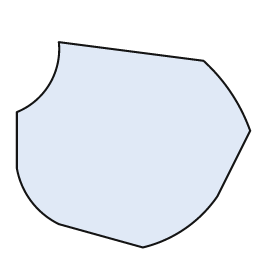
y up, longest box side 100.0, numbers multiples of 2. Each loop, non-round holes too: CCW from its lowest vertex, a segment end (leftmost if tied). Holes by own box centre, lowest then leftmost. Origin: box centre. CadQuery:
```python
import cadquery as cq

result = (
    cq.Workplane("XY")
    .moveTo(4.0, -44.0)
    .threePointArc((22.0, -36.0), (36.0, -22.0))
    .lineTo(50.0, 6.0)
    .threePointArc((42.0, 22.0), (30.0, 36.0))
    .lineTo(-32.0, 44.0)
    .threePointArc((-36.0, 26.0), (-50.0, 14.0))
    .lineTo(-50.0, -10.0)
    .threePointArc((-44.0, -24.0), (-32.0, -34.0))
    .close()
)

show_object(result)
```